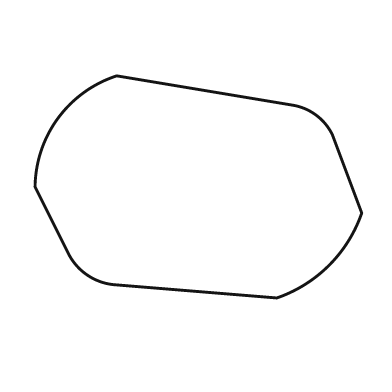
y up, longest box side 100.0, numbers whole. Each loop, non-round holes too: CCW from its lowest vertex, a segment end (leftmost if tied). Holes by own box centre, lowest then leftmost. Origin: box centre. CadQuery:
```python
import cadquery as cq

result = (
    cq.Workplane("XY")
    .moveTo(24.0, -34.0)
    .threePointArc((40.0, -24.0), (50.0, -8.0))
    .lineTo(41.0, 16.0)
    .threePointArc((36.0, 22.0), (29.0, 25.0))
    .lineTo(-25.0, 34.0)
    .threePointArc((-43.0, 21.0), (-50.0, 0.0))
    .lineTo(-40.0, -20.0)
    .threePointArc((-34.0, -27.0), (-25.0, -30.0))
    .close()
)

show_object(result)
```